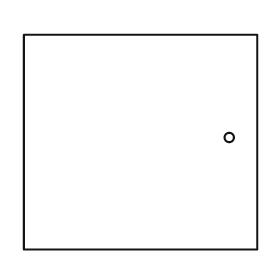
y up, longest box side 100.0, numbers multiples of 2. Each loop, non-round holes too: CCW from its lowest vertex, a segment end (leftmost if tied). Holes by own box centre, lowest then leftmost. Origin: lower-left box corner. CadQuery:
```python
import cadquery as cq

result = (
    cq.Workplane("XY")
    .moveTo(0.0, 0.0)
    .lineTo(100.0, 0.0)
    .lineTo(100.0, 92.0)
    .lineTo(0.0, 92.0)
    .close()
    .moveTo(88.0, 48.0)
    .circle(2.0)
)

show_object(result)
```